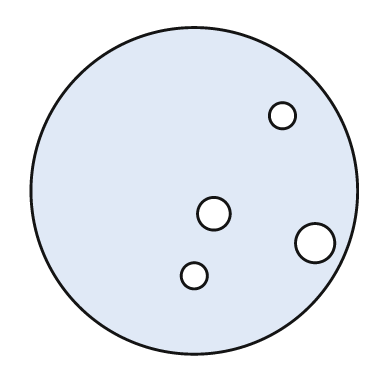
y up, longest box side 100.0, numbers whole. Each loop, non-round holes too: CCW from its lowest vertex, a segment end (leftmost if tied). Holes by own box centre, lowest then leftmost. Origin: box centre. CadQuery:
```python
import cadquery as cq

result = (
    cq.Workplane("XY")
    .moveTo(0.0, 0.0)
    .circle(50.0)
    .moveTo(0.0, -26.0)
    .circle(4.0)
    .moveTo(37.0, -16.0)
    .circle(6.0)
    .moveTo(6.0, -7.0)
    .circle(5.0)
    .moveTo(27.0, 23.0)
    .circle(4.0)
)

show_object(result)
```